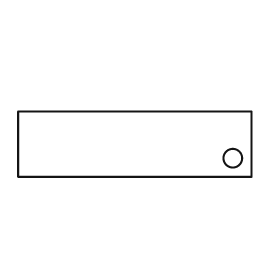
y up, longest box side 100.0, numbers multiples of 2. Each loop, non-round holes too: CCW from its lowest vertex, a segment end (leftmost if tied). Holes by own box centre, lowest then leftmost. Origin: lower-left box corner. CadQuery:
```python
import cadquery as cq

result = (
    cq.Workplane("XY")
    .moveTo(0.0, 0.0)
    .lineTo(100.0, 0.0)
    .lineTo(100.0, 28.0)
    .lineTo(0.0, 28.0)
    .close()
    .moveTo(92.0, 8.0)
    .circle(4.0)
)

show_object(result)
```